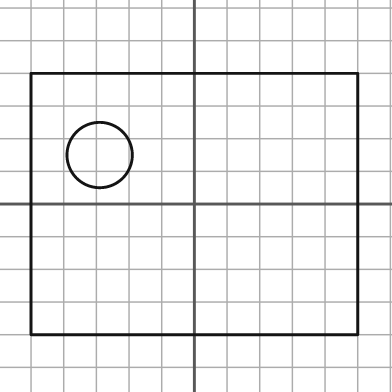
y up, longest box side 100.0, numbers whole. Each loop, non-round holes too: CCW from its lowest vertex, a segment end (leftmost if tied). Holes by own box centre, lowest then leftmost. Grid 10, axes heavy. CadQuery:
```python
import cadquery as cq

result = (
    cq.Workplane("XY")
    .moveTo(-50.0, -40.0)
    .lineTo(50.0, -40.0)
    .lineTo(50.0, 40.0)
    .lineTo(-50.0, 40.0)
    .close()
    .moveTo(-29.0, 15.0)
    .circle(10.0)
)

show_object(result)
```